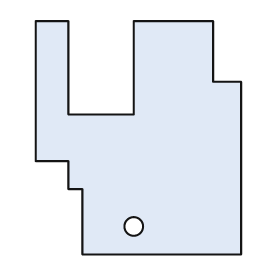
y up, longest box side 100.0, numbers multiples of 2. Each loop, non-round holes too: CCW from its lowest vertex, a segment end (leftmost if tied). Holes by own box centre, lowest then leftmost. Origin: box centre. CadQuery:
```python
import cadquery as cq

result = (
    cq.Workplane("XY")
    .moveTo(-24.0, -50.0)
    .lineTo(44.0, -50.0)
    .lineTo(44.0, 24.0)
    .lineTo(32.0, 24.0)
    .lineTo(32.0, 50.0)
    .lineTo(-2.0, 50.0)
    .lineTo(-2.0, 10.0)
    .lineTo(-30.0, 10.0)
    .lineTo(-30.0, 50.0)
    .lineTo(-44.0, 50.0)
    .lineTo(-44.0, -10.0)
    .lineTo(-30.0, -10.0)
    .lineTo(-30.0, -22.0)
    .lineTo(-24.0, -22.0)
    .close()
    .moveTo(-2.0, -38.0)
    .circle(4.0)
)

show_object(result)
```